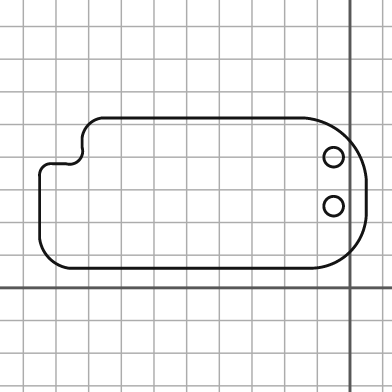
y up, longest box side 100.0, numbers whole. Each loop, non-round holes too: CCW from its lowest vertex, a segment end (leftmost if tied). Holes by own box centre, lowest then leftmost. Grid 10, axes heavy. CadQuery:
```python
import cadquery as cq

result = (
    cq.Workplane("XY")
    .moveTo(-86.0, 6.0)
    .lineTo(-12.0, 6.0)
    .threePointArc((0.0, 11.0), (5.0, 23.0))
    .lineTo(5.0, 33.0)
    .threePointArc((-1.0, 46.0), (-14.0, 52.0))
    .lineTo(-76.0, 52.0)
    .threePointArc((-80.0, 50.0), (-82.0, 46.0))
    .lineTo(-82.0, 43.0)
    .threePointArc((-83.0, 39.0), (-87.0, 38.0))
    .lineTo(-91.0, 38.0)
    .threePointArc((-94.0, 37.0), (-95.0, 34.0))
    .lineTo(-95.0, 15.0)
    .threePointArc((-92.0, 9.0), (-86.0, 6.0))
    .close()
    .moveTo(-5.0, 25.0)
    .circle(3.0)
    .moveTo(-5.0, 40.0)
    .circle(3.0)
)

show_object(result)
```